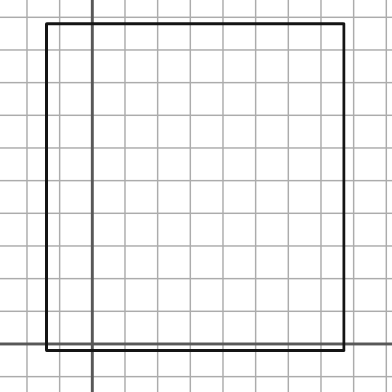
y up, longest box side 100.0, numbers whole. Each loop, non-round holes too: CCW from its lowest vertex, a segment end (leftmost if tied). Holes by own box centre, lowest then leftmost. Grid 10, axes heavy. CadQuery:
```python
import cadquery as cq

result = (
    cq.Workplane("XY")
    .moveTo(-14.0, -2.0)
    .lineTo(77.0, -2.0)
    .lineTo(77.0, 98.0)
    .lineTo(-14.0, 98.0)
    .close()
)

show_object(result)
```